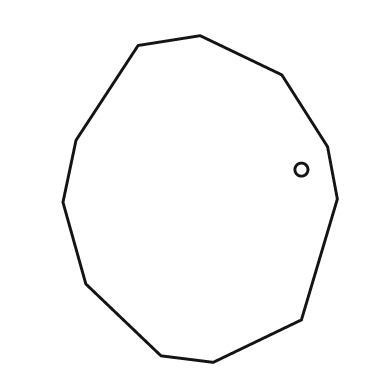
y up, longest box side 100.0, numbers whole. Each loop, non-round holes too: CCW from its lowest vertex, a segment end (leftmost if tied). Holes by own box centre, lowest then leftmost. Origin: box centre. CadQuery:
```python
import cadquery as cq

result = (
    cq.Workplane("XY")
    .moveTo(4.0, -50.0)
    .lineTo(31.0, -37.0)
    .lineTo(42.0, 0.0)
    .lineTo(39.0, 16.0)
    .lineTo(25.0, 38.0)
    .lineTo(0.0, 50.0)
    .lineTo(-19.0, 47.0)
    .lineTo(-38.0, 18.0)
    .lineTo(-42.0, -1.0)
    .lineTo(-35.0, -26.0)
    .lineTo(-12.0, -48.0)
    .close()
    .moveTo(31.0, 9.0)
    .circle(2.0)
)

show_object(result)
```